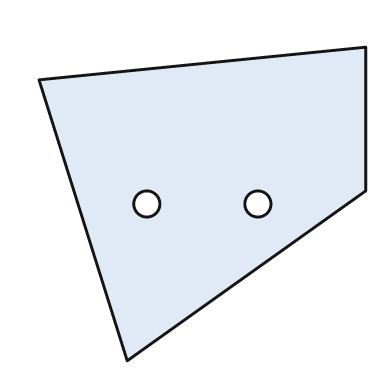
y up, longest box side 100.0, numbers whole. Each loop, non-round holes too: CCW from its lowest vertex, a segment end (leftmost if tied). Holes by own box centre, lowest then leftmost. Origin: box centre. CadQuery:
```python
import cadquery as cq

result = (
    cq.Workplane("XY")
    .moveTo(-23.0, -48.0)
    .lineTo(50.0, 4.0)
    .lineTo(50.0, 48.0)
    .lineTo(-50.0, 38.0)
    .close()
    .moveTo(-17.0, 0.0)
    .circle(4.0)
    .moveTo(17.0, 0.0)
    .circle(4.0)
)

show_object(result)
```